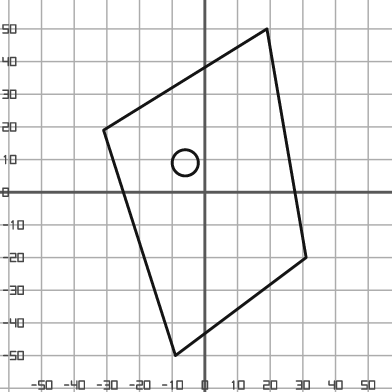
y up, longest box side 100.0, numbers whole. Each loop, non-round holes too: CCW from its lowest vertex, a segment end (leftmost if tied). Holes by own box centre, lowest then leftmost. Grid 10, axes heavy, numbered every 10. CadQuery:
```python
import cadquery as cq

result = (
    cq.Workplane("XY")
    .moveTo(-9.0, -50.0)
    .lineTo(31.0, -20.0)
    .lineTo(19.0, 50.0)
    .lineTo(-31.0, 19.0)
    .close()
    .moveTo(-6.0, 9.0)
    .circle(4.0)
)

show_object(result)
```